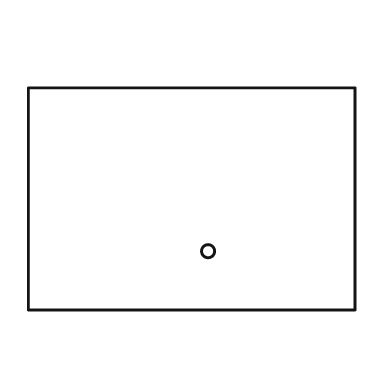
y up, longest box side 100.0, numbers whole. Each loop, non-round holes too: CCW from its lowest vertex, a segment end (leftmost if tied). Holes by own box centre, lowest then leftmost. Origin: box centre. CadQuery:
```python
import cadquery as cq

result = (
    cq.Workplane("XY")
    .moveTo(-50.0, -34.0)
    .lineTo(50.0, -34.0)
    .lineTo(50.0, 34.0)
    .lineTo(-50.0, 34.0)
    .close()
    .moveTo(5.0, -16.0)
    .circle(2.0)
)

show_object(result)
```